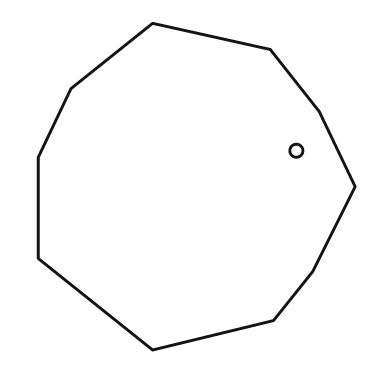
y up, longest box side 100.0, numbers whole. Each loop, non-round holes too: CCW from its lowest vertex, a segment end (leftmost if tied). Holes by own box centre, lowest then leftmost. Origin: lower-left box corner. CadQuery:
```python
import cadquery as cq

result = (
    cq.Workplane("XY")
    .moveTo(35.0, 0.0)
    .lineTo(72.0, 9.0)
    .lineTo(84.0, 24.0)
    .lineTo(97.0, 50.0)
    .lineTo(86.0, 73.0)
    .lineTo(71.0, 92.0)
    .lineTo(35.0, 100.0)
    .lineTo(10.0, 80.0)
    .lineTo(0.0, 59.0)
    .lineTo(0.0, 28.0)
    .close()
    .moveTo(79.0, 61.0)
    .circle(2.0)
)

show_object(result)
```